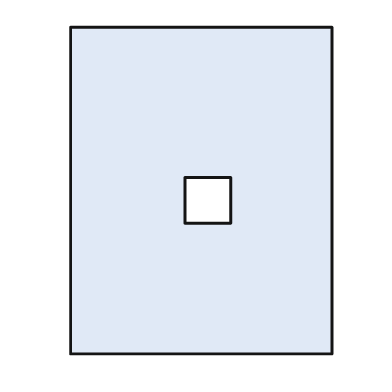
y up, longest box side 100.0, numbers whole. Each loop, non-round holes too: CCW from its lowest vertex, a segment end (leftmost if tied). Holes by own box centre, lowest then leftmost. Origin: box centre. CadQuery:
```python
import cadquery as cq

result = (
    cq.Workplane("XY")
    .moveTo(-40.0, -50.0)
    .lineTo(40.0, -50.0)
    .lineTo(40.0, 50.0)
    .lineTo(-40.0, 50.0)
    .close()
    .moveTo(-5.0, -10.0)
    .lineTo(9.0, -10.0)
    .lineTo(9.0, 4.0)
    .lineTo(-5.0, 4.0)
    .close()
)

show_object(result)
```